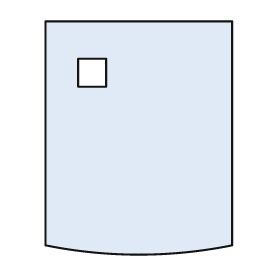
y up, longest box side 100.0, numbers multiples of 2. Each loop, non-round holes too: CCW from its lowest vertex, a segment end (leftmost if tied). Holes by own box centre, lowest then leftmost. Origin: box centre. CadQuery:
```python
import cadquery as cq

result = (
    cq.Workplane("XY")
    .moveTo(-40.0, -46.0)
    .threePointArc((0.0, -50.0), (40.0, -46.0))
    .lineTo(40.0, 50.0)
    .lineTo(-40.0, 50.0)
    .close()
    .moveTo(-26.0, 22.0)
    .lineTo(-14.0, 22.0)
    .lineTo(-14.0, 34.0)
    .lineTo(-26.0, 34.0)
    .close()
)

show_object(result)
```